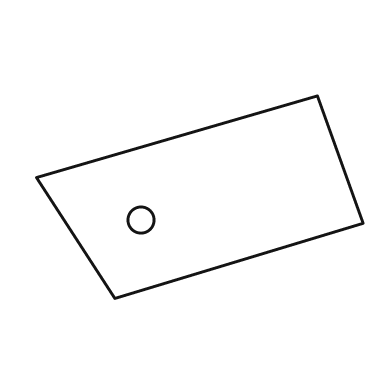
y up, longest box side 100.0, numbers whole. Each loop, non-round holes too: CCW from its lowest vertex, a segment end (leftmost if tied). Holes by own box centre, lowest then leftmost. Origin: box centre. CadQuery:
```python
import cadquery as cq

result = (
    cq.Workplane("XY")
    .moveTo(-26.0, -31.0)
    .lineTo(50.0, -8.0)
    .lineTo(36.0, 31.0)
    .lineTo(-50.0, 6.0)
    .close()
    .moveTo(-18.0, -7.0)
    .circle(4.0)
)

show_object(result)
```